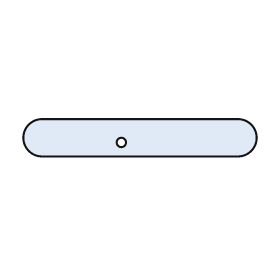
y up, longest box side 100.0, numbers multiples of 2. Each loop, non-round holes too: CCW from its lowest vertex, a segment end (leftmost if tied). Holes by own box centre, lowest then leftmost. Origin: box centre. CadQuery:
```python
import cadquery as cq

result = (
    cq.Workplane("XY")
    .moveTo(-42.0, -8.0)
    .lineTo(42.0, -8.0)
    .threePointArc((50.0, 0.0), (42.0, 8.0))
    .lineTo(-42.0, 8.0)
    .threePointArc((-50.0, 0.0), (-42.0, -8.0))
    .close()
    .moveTo(-8.0, -2.0)
    .circle(2.0)
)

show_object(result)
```